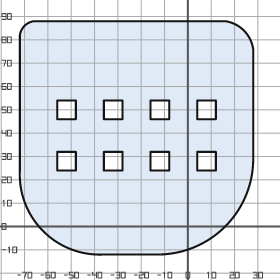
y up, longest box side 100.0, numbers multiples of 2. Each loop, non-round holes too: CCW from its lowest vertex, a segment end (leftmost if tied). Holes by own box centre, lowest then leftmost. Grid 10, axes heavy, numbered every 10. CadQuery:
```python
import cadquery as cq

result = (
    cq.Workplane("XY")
    .moveTo(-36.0, -12.0)
    .lineTo(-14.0, -12.0)
    .threePointArc((16.0, 0.0), (28.0, 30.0))
    .lineTo(28.0, 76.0)
    .threePointArc((24.0, 84.0), (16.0, 88.0))
    .lineTo(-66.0, 88.0)
    .threePointArc((-70.0, 86.0), (-72.0, 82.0))
    .lineTo(-72.0, 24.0)
    .threePointArc((-62.0, -2.0), (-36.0, -12.0))
    .close()
    .moveTo(-56.0, 24.0)
    .lineTo(-48.0, 24.0)
    .lineTo(-48.0, 32.0)
    .lineTo(-56.0, 32.0)
    .close()
    .moveTo(-36.0, 24.0)
    .lineTo(-28.0, 24.0)
    .lineTo(-28.0, 32.0)
    .lineTo(-36.0, 32.0)
    .close()
    .moveTo(-16.0, 24.0)
    .lineTo(-8.0, 24.0)
    .lineTo(-8.0, 32.0)
    .lineTo(-16.0, 32.0)
    .close()
    .moveTo(4.0, 24.0)
    .lineTo(12.0, 24.0)
    .lineTo(12.0, 32.0)
    .lineTo(4.0, 32.0)
    .close()
    .moveTo(-56.0, 46.0)
    .lineTo(-48.0, 46.0)
    .lineTo(-48.0, 54.0)
    .lineTo(-56.0, 54.0)
    .close()
    .moveTo(-36.0, 46.0)
    .lineTo(-28.0, 46.0)
    .lineTo(-28.0, 54.0)
    .lineTo(-36.0, 54.0)
    .close()
    .moveTo(-16.0, 46.0)
    .lineTo(-8.0, 46.0)
    .lineTo(-8.0, 54.0)
    .lineTo(-16.0, 54.0)
    .close()
    .moveTo(4.0, 46.0)
    .lineTo(12.0, 46.0)
    .lineTo(12.0, 54.0)
    .lineTo(4.0, 54.0)
    .close()
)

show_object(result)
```